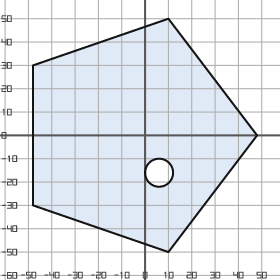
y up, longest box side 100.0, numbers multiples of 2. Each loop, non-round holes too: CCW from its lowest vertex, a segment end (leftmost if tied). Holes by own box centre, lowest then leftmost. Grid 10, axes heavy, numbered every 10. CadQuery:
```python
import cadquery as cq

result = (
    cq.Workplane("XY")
    .moveTo(10.0, -50.0)
    .lineTo(48.0, 0.0)
    .lineTo(10.0, 50.0)
    .lineTo(-48.0, 30.0)
    .lineTo(-48.0, -30.0)
    .close()
    .moveTo(6.0, -16.0)
    .circle(6.0)
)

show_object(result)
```